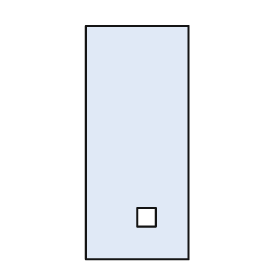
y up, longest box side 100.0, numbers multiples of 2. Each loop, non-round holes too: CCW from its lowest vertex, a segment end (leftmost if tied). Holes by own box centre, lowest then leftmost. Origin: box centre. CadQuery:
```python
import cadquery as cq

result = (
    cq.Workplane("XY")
    .moveTo(-22.0, -50.0)
    .lineTo(22.0, -50.0)
    .lineTo(22.0, 50.0)
    .lineTo(-22.0, 50.0)
    .close()
    .moveTo(0.0, -36.0)
    .lineTo(8.0, -36.0)
    .lineTo(8.0, -28.0)
    .lineTo(0.0, -28.0)
    .close()
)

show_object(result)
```